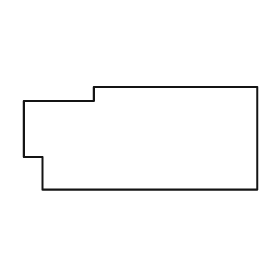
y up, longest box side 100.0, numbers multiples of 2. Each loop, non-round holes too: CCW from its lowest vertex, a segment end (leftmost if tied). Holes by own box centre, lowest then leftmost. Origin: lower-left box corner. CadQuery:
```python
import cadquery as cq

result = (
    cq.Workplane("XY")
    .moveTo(8.0, 0.0)
    .lineTo(100.0, 0.0)
    .lineTo(100.0, 44.0)
    .lineTo(30.0, 44.0)
    .lineTo(30.0, 38.0)
    .lineTo(0.0, 38.0)
    .lineTo(0.0, 14.0)
    .lineTo(8.0, 14.0)
    .close()
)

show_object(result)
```